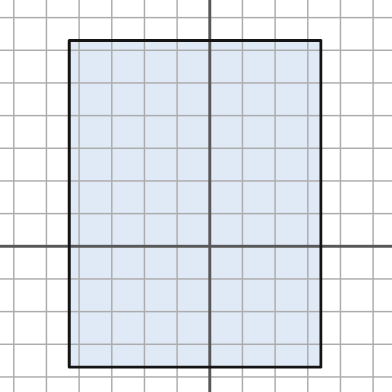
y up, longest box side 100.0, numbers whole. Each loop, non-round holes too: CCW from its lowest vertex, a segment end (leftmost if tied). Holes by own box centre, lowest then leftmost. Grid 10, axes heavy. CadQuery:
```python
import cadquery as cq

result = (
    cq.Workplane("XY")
    .moveTo(-43.0, -37.0)
    .lineTo(34.0, -37.0)
    .lineTo(34.0, 63.0)
    .lineTo(-43.0, 63.0)
    .close()
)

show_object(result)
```